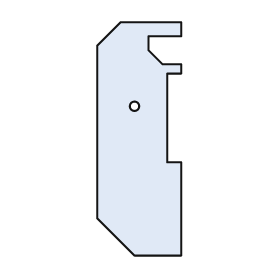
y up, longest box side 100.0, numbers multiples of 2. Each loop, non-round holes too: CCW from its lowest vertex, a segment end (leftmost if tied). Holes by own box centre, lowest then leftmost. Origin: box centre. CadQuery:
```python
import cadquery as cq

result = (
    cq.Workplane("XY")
    .moveTo(-2.0, -50.0)
    .lineTo(18.0, -50.0)
    .lineTo(18.0, -10.0)
    .lineTo(12.0, -10.0)
    .lineTo(12.0, 28.0)
    .lineTo(18.0, 28.0)
    .lineTo(18.0, 32.0)
    .lineTo(10.0, 32.0)
    .lineTo(4.0, 38.0)
    .lineTo(4.0, 44.0)
    .lineTo(18.0, 44.0)
    .lineTo(18.0, 50.0)
    .lineTo(-8.0, 50.0)
    .lineTo(-18.0, 40.0)
    .lineTo(-18.0, -34.0)
    .close()
    .moveTo(-2.0, 14.0)
    .circle(2.0)
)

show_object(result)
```